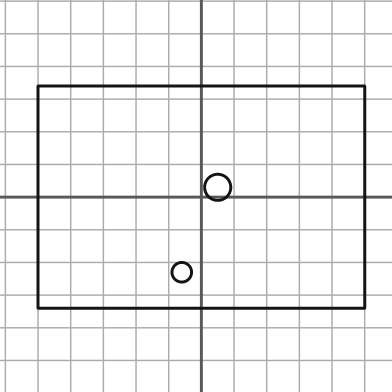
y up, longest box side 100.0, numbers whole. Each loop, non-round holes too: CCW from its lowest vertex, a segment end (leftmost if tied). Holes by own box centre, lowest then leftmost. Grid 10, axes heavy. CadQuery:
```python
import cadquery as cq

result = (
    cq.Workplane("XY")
    .moveTo(-50.0, -34.0)
    .lineTo(50.0, -34.0)
    .lineTo(50.0, 34.0)
    .lineTo(-50.0, 34.0)
    .close()
    .moveTo(-6.0, -23.0)
    .circle(3.0)
    .moveTo(5.0, 3.0)
    .circle(4.0)
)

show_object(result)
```